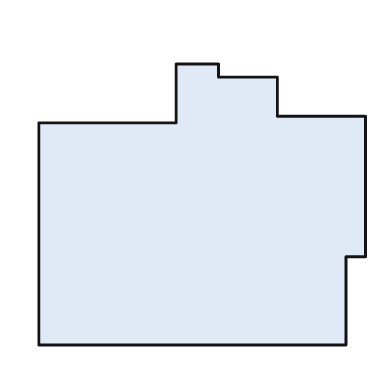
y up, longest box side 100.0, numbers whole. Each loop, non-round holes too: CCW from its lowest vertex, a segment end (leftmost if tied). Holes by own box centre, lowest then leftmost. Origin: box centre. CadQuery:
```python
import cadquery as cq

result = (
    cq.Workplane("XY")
    .moveTo(-50.0, -43.0)
    .lineTo(44.0, -43.0)
    .lineTo(44.0, -16.0)
    .lineTo(50.0, -16.0)
    .lineTo(50.0, 27.0)
    .lineTo(23.0, 27.0)
    .lineTo(23.0, 39.0)
    .lineTo(5.0, 39.0)
    .lineTo(5.0, 43.0)
    .lineTo(-8.0, 43.0)
    .lineTo(-8.0, 25.0)
    .lineTo(-50.0, 25.0)
    .close()
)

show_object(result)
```